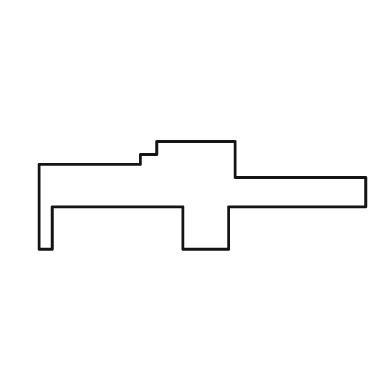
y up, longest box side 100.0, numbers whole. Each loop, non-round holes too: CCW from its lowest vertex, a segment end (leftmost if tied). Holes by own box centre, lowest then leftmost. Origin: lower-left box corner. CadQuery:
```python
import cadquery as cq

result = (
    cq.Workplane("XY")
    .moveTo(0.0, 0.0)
    .lineTo(4.0, 0.0)
    .lineTo(4.0, 13.0)
    .lineTo(44.0, 13.0)
    .lineTo(44.0, 0.0)
    .lineTo(58.0, 0.0)
    .lineTo(58.0, 13.0)
    .lineTo(100.0, 13.0)
    .lineTo(100.0, 22.0)
    .lineTo(60.0, 22.0)
    .lineTo(60.0, 33.0)
    .lineTo(36.0, 33.0)
    .lineTo(36.0, 29.0)
    .lineTo(31.0, 29.0)
    .lineTo(31.0, 26.0)
    .lineTo(0.0, 26.0)
    .close()
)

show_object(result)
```